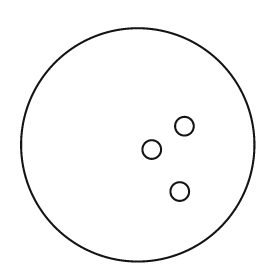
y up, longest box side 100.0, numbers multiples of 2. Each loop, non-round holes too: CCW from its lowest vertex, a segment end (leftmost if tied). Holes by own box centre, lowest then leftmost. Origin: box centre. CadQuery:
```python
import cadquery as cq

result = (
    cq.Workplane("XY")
    .moveTo(0.0, 0.0)
    .circle(50.0)
    .moveTo(18.0, -20.0)
    .circle(4.0)
    .moveTo(6.0, -2.0)
    .circle(4.0)
    .moveTo(20.0, 8.0)
    .circle(4.0)
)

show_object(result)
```